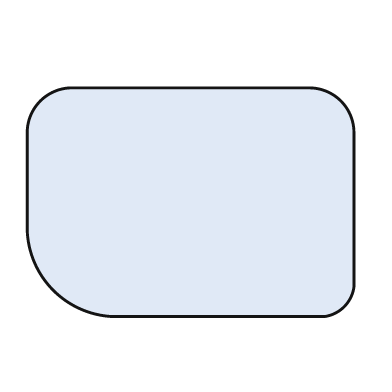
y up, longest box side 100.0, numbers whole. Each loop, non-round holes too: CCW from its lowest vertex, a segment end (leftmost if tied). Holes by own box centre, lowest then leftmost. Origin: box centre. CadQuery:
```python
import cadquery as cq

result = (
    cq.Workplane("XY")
    .moveTo(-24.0, -35.0)
    .lineTo(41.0, -35.0)
    .threePointArc((47.0, -32.0), (50.0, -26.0))
    .lineTo(50.0, 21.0)
    .threePointArc((46.0, 31.0), (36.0, 35.0))
    .lineTo(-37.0, 35.0)
    .threePointArc((-46.0, 31.0), (-50.0, 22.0))
    .lineTo(-50.0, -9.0)
    .threePointArc((-42.0, -27.0), (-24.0, -35.0))
    .close()
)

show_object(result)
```